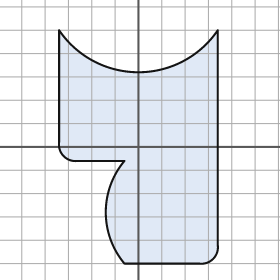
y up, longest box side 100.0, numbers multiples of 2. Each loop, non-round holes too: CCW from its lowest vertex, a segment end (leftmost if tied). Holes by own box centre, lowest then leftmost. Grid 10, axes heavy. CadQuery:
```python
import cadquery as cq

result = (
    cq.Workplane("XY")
    .moveTo(-6.0, -50.0)
    .lineTo(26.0, -50.0)
    .threePointArc((32.0, -48.0), (34.0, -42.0))
    .lineTo(34.0, 50.0)
    .threePointArc((0.0, 32.0), (-34.0, 50.0))
    .lineTo(-34.0, 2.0)
    .threePointArc((-32.0, -4.0), (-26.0, -6.0))
    .lineTo(-6.0, -6.0)
    .threePointArc((-14.0, -28.0), (-6.0, -50.0))
    .close()
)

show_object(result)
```